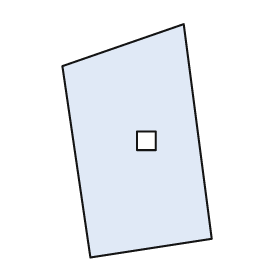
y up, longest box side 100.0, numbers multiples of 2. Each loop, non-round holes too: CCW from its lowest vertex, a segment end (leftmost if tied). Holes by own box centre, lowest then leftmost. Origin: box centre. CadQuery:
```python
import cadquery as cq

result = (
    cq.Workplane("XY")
    .moveTo(-20.0, -50.0)
    .lineTo(32.0, -42.0)
    .lineTo(20.0, 50.0)
    .lineTo(-32.0, 32.0)
    .close()
    .moveTo(0.0, -4.0)
    .lineTo(8.0, -4.0)
    .lineTo(8.0, 4.0)
    .lineTo(0.0, 4.0)
    .close()
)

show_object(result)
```